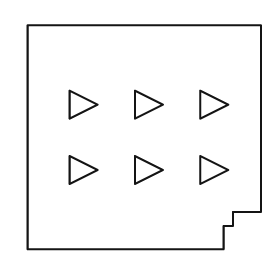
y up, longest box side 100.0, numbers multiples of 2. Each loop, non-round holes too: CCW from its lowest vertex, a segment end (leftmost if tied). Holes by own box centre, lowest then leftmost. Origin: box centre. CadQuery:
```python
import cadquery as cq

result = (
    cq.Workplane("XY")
    .moveTo(-50.0, -48.0)
    .lineTo(34.0, -48.0)
    .lineTo(34.0, -38.0)
    .lineTo(38.0, -38.0)
    .lineTo(38.0, -32.0)
    .lineTo(50.0, -32.0)
    .lineTo(50.0, 48.0)
    .lineTo(-50.0, 48.0)
    .close()
    .moveTo(-32.0, -20.0)
    .lineTo(-20.0, -14.0)
    .lineTo(-32.0, -8.0)
    .close()
    .moveTo(-4.0, -20.0)
    .lineTo(8.0, -14.0)
    .lineTo(-4.0, -8.0)
    .close()
    .moveTo(24.0, -20.0)
    .lineTo(36.0, -14.0)
    .lineTo(24.0, -8.0)
    .close()
    .moveTo(-32.0, 8.0)
    .lineTo(-20.0, 14.0)
    .lineTo(-32.0, 20.0)
    .close()
    .moveTo(-4.0, 8.0)
    .lineTo(8.0, 14.0)
    .lineTo(-4.0, 20.0)
    .close()
    .moveTo(24.0, 8.0)
    .lineTo(36.0, 14.0)
    .lineTo(24.0, 20.0)
    .close()
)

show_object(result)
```